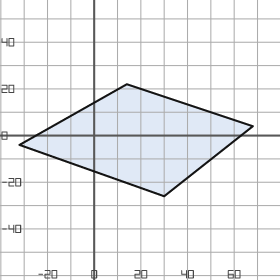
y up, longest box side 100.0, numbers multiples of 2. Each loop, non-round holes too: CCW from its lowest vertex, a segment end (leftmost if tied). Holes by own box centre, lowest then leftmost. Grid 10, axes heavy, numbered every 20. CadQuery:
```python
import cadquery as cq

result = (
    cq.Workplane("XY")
    .moveTo(30.0, -26.0)
    .lineTo(68.0, 4.0)
    .lineTo(14.0, 22.0)
    .lineTo(-32.0, -4.0)
    .close()
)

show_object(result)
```